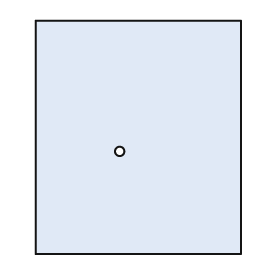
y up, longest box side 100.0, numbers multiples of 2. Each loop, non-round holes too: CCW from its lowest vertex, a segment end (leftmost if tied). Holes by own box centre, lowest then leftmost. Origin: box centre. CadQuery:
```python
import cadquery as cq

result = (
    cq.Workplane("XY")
    .moveTo(-44.0, -50.0)
    .lineTo(44.0, -50.0)
    .lineTo(44.0, 50.0)
    .lineTo(-44.0, 50.0)
    .close()
    .moveTo(-8.0, -6.0)
    .circle(2.0)
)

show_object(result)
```